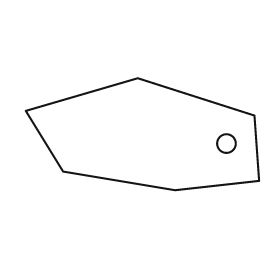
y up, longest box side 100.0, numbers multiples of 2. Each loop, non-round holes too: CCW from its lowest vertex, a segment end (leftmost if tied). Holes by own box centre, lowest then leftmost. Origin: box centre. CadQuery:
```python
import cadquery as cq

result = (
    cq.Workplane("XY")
    .moveTo(14.0, -24.0)
    .lineTo(50.0, -20.0)
    .lineTo(48.0, 8.0)
    .lineTo(-2.0, 24.0)
    .lineTo(-50.0, 10.0)
    .lineTo(-34.0, -16.0)
    .close()
    .moveTo(36.0, -4.0)
    .circle(4.0)
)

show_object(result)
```